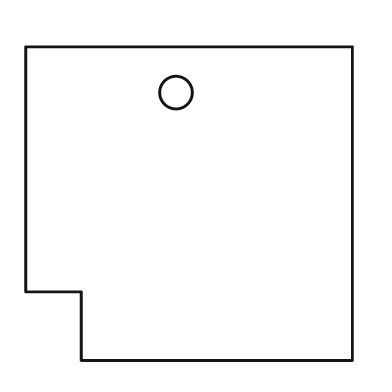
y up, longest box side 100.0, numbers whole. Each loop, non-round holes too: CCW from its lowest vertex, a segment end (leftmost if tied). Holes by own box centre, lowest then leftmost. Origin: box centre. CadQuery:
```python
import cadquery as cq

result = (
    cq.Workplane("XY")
    .moveTo(-33.0, -48.0)
    .lineTo(50.0, -48.0)
    .lineTo(50.0, 48.0)
    .lineTo(-50.0, 48.0)
    .lineTo(-50.0, -27.0)
    .lineTo(-33.0, -27.0)
    .close()
    .moveTo(-4.0, 34.0)
    .circle(5.0)
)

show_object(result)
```